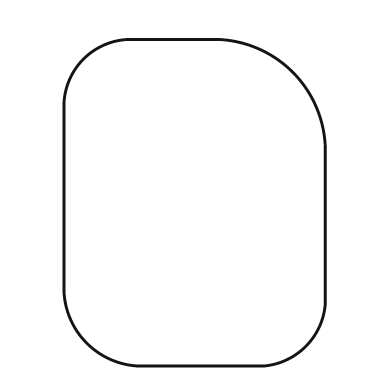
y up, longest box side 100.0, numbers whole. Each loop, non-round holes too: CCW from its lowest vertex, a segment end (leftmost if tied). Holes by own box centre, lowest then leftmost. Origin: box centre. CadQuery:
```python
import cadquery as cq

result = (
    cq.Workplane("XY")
    .moveTo(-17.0, -50.0)
    .lineTo(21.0, -50.0)
    .threePointArc((34.0, -44.0), (40.0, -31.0))
    .lineTo(40.0, 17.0)
    .threePointArc((30.0, 40.0), (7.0, 50.0))
    .lineTo(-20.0, 50.0)
    .threePointArc((-34.0, 44.0), (-40.0, 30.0))
    .lineTo(-40.0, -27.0)
    .threePointArc((-33.0, -43.0), (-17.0, -50.0))
    .close()
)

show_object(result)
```